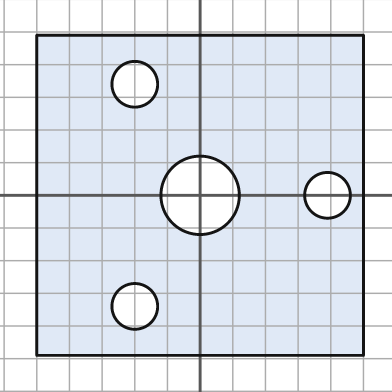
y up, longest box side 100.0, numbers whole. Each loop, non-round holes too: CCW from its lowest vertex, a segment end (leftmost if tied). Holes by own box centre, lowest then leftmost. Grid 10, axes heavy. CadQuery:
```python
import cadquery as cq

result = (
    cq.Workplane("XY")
    .moveTo(-50.0, -49.0)
    .lineTo(50.0, -49.0)
    .lineTo(50.0, 49.0)
    .lineTo(-50.0, 49.0)
    .close()
    .moveTo(-20.0, -34.0)
    .circle(7.0)
    .moveTo(0.0, 0.0)
    .circle(12.0)
    .moveTo(39.0, 0.0)
    .circle(7.0)
    .moveTo(-20.0, 34.0)
    .circle(7.0)
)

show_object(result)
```